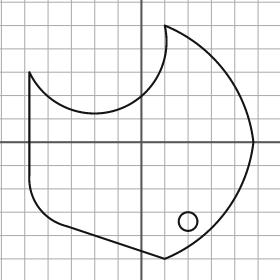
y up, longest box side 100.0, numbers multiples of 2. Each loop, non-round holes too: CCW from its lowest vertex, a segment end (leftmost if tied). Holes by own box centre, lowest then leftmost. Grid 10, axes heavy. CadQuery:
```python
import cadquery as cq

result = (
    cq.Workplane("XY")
    .moveTo(10.0, -50.0)
    .threePointArc((36.0, -30.0), (48.0, 0.0))
    .threePointArc((36.0, 30.0), (10.0, 50.0))
    .threePointArc((-10.0, 14.0), (-48.0, 30.0))
    .lineTo(-48.0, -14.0)
    .threePointArc((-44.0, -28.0), (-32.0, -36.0))
    .close()
    .moveTo(20.0, -34.0)
    .circle(4.0)
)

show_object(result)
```